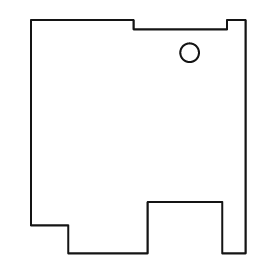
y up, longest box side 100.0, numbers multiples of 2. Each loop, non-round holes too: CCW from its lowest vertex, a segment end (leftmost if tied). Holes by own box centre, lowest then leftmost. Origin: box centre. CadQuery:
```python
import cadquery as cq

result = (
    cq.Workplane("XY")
    .moveTo(-30.0, -50.0)
    .lineTo(4.0, -50.0)
    .lineTo(4.0, -28.0)
    .lineTo(36.0, -28.0)
    .lineTo(36.0, -50.0)
    .lineTo(46.0, -50.0)
    .lineTo(46.0, 50.0)
    .lineTo(38.0, 50.0)
    .lineTo(38.0, 46.0)
    .lineTo(-2.0, 46.0)
    .lineTo(-2.0, 50.0)
    .lineTo(-46.0, 50.0)
    .lineTo(-46.0, -38.0)
    .lineTo(-30.0, -38.0)
    .close()
    .moveTo(22.0, 36.0)
    .circle(4.0)
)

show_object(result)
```